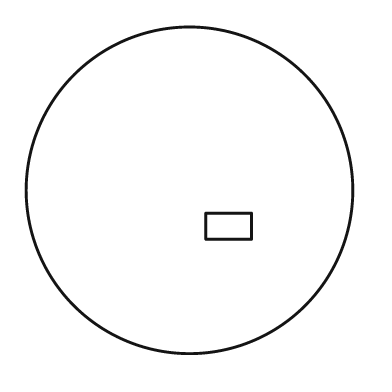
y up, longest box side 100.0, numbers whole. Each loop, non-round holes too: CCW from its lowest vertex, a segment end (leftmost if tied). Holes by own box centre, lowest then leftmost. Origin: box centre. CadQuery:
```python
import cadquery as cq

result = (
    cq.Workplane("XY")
    .moveTo(0.0, 0.0)
    .circle(50.0)
    .moveTo(5.0, -15.0)
    .lineTo(19.0, -15.0)
    .lineTo(19.0, -7.0)
    .lineTo(5.0, -7.0)
    .close()
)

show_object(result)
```